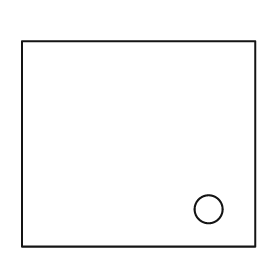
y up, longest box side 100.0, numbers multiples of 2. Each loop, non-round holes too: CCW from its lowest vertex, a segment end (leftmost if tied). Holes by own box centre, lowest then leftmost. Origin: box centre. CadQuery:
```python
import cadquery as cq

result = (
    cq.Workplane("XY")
    .moveTo(-50.0, -44.0)
    .lineTo(50.0, -44.0)
    .lineTo(50.0, 44.0)
    .lineTo(-50.0, 44.0)
    .close()
    .moveTo(30.0, -28.0)
    .circle(6.0)
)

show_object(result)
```